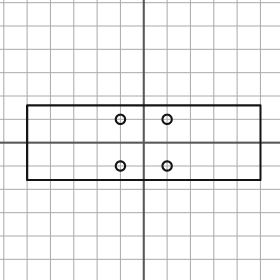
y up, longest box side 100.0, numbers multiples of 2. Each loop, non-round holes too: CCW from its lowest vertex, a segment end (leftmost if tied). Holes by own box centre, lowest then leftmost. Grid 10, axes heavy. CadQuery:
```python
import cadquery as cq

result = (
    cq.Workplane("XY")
    .moveTo(-50.0, -16.0)
    .lineTo(50.0, -16.0)
    .lineTo(50.0, 16.0)
    .lineTo(-50.0, 16.0)
    .close()
    .moveTo(-10.0, -10.0)
    .circle(2.0)
    .moveTo(10.0, -10.0)
    .circle(2.0)
    .moveTo(-10.0, 10.0)
    .circle(2.0)
    .moveTo(10.0, 10.0)
    .circle(2.0)
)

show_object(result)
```